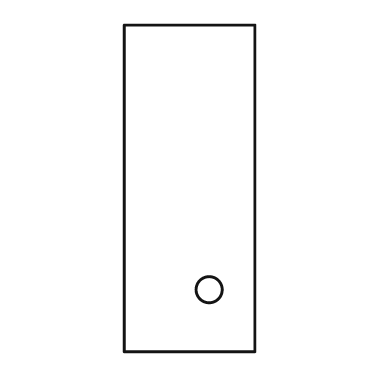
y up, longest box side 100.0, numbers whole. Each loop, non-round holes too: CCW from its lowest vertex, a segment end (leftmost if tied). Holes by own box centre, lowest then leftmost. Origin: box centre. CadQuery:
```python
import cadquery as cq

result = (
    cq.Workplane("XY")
    .moveTo(-20.0, -50.0)
    .lineTo(20.0, -50.0)
    .lineTo(20.0, 50.0)
    .lineTo(-20.0, 50.0)
    .close()
    .moveTo(6.0, -31.0)
    .circle(4.0)
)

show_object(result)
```